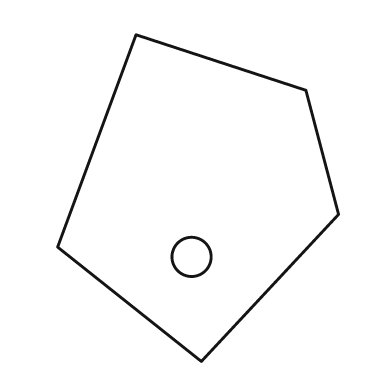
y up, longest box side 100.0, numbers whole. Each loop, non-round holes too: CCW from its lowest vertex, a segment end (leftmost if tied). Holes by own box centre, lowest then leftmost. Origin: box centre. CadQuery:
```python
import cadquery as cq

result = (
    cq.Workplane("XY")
    .moveTo(1.0, -50.0)
    .lineTo(43.0, -5.0)
    .lineTo(33.0, 33.0)
    .lineTo(-19.0, 50.0)
    .lineTo(-43.0, -15.0)
    .close()
    .moveTo(-2.0, -18.0)
    .circle(6.0)
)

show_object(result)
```